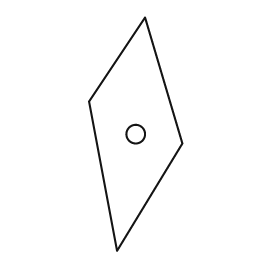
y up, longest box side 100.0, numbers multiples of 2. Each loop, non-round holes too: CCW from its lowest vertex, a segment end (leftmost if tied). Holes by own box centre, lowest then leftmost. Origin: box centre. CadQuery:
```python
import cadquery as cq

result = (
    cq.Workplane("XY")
    .moveTo(-8.0, -50.0)
    .lineTo(20.0, -4.0)
    .lineTo(4.0, 50.0)
    .lineTo(-20.0, 14.0)
    .close()
    .moveTo(0.0, 0.0)
    .circle(4.0)
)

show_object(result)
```